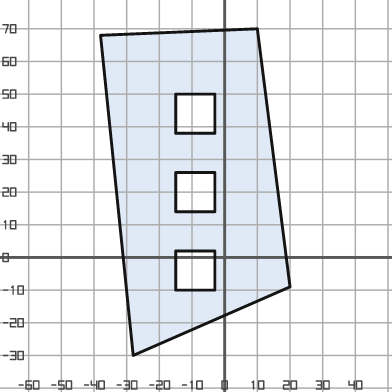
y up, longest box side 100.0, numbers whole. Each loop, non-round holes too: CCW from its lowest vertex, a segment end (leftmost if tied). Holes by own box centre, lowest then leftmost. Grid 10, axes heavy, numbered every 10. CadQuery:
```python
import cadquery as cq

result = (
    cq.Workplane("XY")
    .moveTo(-28.0, -30.0)
    .lineTo(20.0, -9.0)
    .lineTo(10.0, 70.0)
    .lineTo(-38.0, 68.0)
    .close()
    .moveTo(-15.0, -10.0)
    .lineTo(-3.0, -10.0)
    .lineTo(-3.0, 2.0)
    .lineTo(-15.0, 2.0)
    .close()
    .moveTo(-15.0, 14.0)
    .lineTo(-3.0, 14.0)
    .lineTo(-3.0, 26.0)
    .lineTo(-15.0, 26.0)
    .close()
    .moveTo(-15.0, 38.0)
    .lineTo(-3.0, 38.0)
    .lineTo(-3.0, 50.0)
    .lineTo(-15.0, 50.0)
    .close()
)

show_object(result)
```